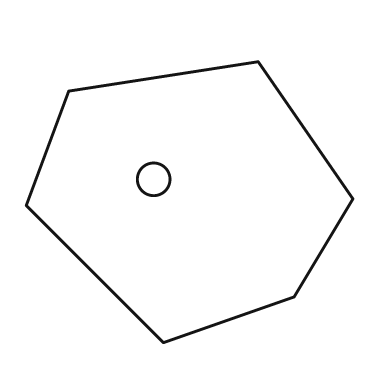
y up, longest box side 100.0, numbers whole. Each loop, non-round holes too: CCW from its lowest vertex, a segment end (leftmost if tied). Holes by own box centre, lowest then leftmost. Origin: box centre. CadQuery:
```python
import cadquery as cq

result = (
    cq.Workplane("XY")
    .moveTo(-8.0, -43.0)
    .lineTo(32.0, -29.0)
    .lineTo(50.0, 1.0)
    .lineTo(21.0, 43.0)
    .lineTo(-37.0, 34.0)
    .lineTo(-50.0, -1.0)
    .close()
    .moveTo(-11.0, 7.0)
    .circle(5.0)
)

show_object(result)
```